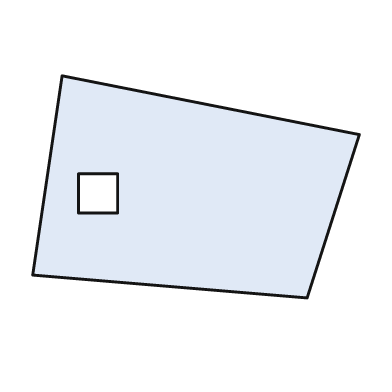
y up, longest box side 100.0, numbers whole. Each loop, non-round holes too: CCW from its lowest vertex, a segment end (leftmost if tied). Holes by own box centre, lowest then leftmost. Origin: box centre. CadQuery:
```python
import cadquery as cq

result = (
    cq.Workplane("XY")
    .moveTo(34.0, -34.0)
    .lineTo(50.0, 16.0)
    .lineTo(-41.0, 34.0)
    .lineTo(-50.0, -27.0)
    .close()
    .moveTo(-36.0, -8.0)
    .lineTo(-24.0, -8.0)
    .lineTo(-24.0, 4.0)
    .lineTo(-36.0, 4.0)
    .close()
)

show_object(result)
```